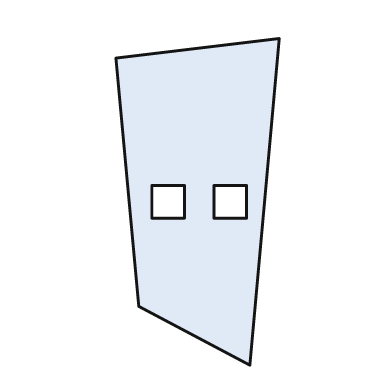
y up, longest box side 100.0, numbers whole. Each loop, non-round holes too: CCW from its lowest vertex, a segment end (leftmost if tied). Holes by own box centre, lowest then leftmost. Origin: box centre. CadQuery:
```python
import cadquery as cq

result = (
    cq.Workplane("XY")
    .moveTo(16.0, -50.0)
    .lineTo(25.0, 50.0)
    .lineTo(-25.0, 44.0)
    .lineTo(-18.0, -32.0)
    .close()
    .moveTo(-14.0, -5.0)
    .lineTo(-4.0, -5.0)
    .lineTo(-4.0, 5.0)
    .lineTo(-14.0, 5.0)
    .close()
    .moveTo(5.0, -5.0)
    .lineTo(15.0, -5.0)
    .lineTo(15.0, 5.0)
    .lineTo(5.0, 5.0)
    .close()
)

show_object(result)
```